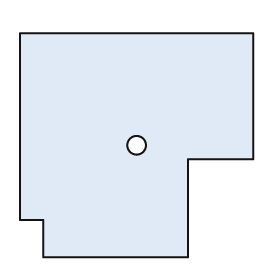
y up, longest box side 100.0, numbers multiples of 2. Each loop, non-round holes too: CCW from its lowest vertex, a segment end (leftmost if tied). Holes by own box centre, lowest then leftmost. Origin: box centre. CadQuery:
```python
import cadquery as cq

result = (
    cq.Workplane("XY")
    .moveTo(-40.0, -48.0)
    .lineTo(22.0, -48.0)
    .lineTo(22.0, -6.0)
    .lineTo(50.0, -6.0)
    .lineTo(50.0, 48.0)
    .lineTo(-50.0, 48.0)
    .lineTo(-50.0, -32.0)
    .lineTo(-40.0, -32.0)
    .close()
    .moveTo(0.0, 0.0)
    .circle(4.0)
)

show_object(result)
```